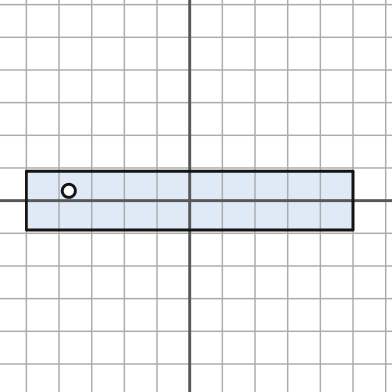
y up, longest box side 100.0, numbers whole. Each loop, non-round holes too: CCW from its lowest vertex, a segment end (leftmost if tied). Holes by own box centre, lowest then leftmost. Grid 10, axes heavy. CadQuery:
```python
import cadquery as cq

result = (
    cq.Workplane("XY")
    .moveTo(-50.0, -9.0)
    .lineTo(50.0, -9.0)
    .lineTo(50.0, 9.0)
    .lineTo(-50.0, 9.0)
    .close()
    .moveTo(-37.0, 3.0)
    .circle(2.0)
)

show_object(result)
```